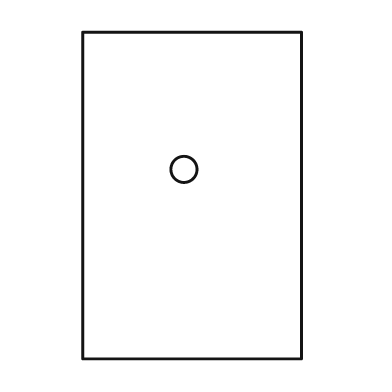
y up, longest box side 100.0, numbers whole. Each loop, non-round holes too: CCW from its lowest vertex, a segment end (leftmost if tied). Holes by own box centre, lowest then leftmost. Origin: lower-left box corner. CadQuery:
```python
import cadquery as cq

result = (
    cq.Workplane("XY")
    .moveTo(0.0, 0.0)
    .lineTo(67.0, 0.0)
    .lineTo(67.0, 100.0)
    .lineTo(0.0, 100.0)
    .close()
    .moveTo(31.0, 58.0)
    .circle(4.0)
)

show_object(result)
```